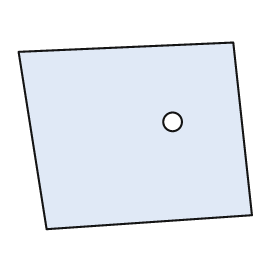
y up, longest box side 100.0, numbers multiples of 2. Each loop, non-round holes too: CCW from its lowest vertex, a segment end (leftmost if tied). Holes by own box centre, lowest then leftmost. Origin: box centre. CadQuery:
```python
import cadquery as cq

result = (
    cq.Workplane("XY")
    .moveTo(-38.0, -40.0)
    .lineTo(50.0, -34.0)
    .lineTo(42.0, 40.0)
    .lineTo(-50.0, 36.0)
    .close()
    .moveTo(16.0, 6.0)
    .circle(4.0)
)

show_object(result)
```